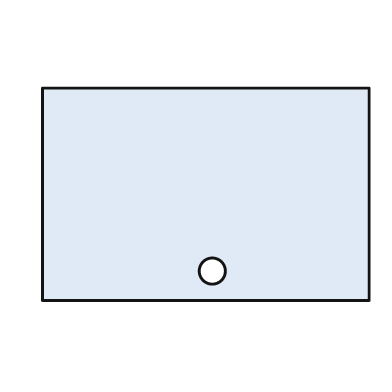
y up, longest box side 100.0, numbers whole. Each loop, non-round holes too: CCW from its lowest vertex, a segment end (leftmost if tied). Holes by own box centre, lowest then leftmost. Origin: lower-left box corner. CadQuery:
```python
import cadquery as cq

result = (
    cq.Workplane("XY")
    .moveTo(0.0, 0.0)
    .lineTo(100.0, 0.0)
    .lineTo(100.0, 65.0)
    .lineTo(0.0, 65.0)
    .close()
    .moveTo(52.0, 9.0)
    .circle(4.0)
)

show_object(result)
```